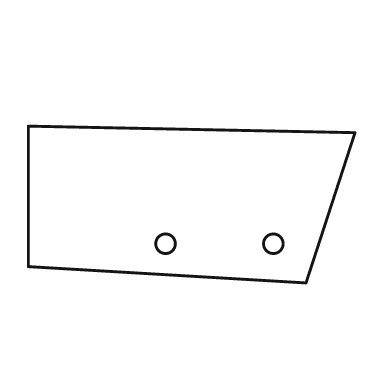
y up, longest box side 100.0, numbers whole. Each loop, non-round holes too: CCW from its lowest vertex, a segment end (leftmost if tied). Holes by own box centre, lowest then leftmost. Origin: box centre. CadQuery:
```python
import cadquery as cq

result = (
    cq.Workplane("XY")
    .moveTo(35.0, -24.0)
    .lineTo(50.0, 22.0)
    .lineTo(-50.0, 24.0)
    .lineTo(-50.0, -19.0)
    .close()
    .moveTo(-8.0, -12.0)
    .circle(3.0)
    .moveTo(25.0, -12.0)
    .circle(3.0)
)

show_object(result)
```